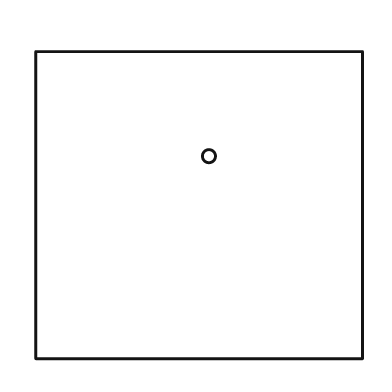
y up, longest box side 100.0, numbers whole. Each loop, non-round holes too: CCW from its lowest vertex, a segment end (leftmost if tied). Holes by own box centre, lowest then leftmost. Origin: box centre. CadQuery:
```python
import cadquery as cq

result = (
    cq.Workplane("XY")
    .moveTo(-50.0, -47.0)
    .lineTo(50.0, -47.0)
    .lineTo(50.0, 47.0)
    .lineTo(-50.0, 47.0)
    .close()
    .moveTo(3.0, 15.0)
    .circle(2.0)
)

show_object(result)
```